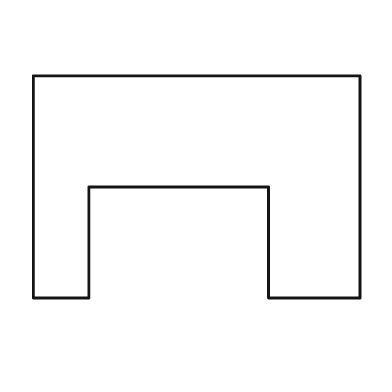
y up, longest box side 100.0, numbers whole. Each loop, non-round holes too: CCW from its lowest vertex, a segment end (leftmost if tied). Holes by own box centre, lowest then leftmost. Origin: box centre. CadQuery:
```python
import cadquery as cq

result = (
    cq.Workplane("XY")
    .moveTo(-50.0, -34.0)
    .lineTo(-33.0, -34.0)
    .lineTo(-33.0, 0.0)
    .lineTo(22.0, 0.0)
    .lineTo(22.0, -34.0)
    .lineTo(50.0, -34.0)
    .lineTo(50.0, 34.0)
    .lineTo(-50.0, 34.0)
    .close()
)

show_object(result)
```